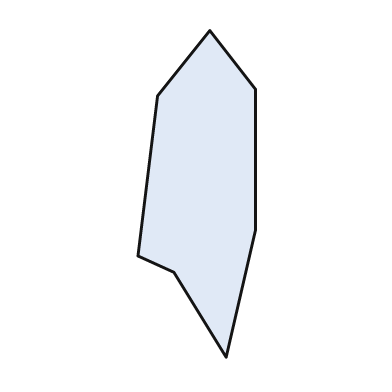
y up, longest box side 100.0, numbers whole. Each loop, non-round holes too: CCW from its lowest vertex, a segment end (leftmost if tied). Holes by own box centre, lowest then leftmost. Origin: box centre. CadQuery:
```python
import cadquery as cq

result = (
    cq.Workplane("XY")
    .moveTo(9.0, -50.0)
    .lineTo(18.0, -11.0)
    .lineTo(18.0, 32.0)
    .lineTo(4.0, 50.0)
    .lineTo(-12.0, 30.0)
    .lineTo(-18.0, -19.0)
    .lineTo(-7.0, -24.0)
    .close()
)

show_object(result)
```